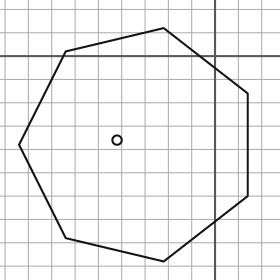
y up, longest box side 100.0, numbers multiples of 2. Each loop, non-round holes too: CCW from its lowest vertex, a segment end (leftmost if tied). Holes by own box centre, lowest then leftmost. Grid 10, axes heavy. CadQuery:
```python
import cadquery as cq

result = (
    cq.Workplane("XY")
    .moveTo(-22.0, -88.0)
    .lineTo(14.0, -60.0)
    .lineTo(14.0, -16.0)
    .lineTo(-22.0, 12.0)
    .lineTo(-64.0, 2.0)
    .lineTo(-84.0, -38.0)
    .lineTo(-64.0, -78.0)
    .close()
    .moveTo(-42.0, -36.0)
    .circle(2.0)
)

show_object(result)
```